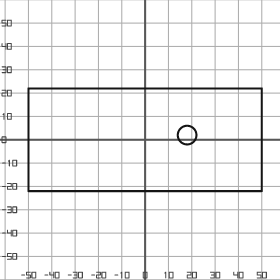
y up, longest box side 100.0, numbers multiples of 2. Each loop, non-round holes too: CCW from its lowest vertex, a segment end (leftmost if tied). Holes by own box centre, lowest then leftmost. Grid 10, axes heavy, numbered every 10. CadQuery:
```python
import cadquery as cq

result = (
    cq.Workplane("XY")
    .moveTo(-50.0, -22.0)
    .lineTo(50.0, -22.0)
    .lineTo(50.0, 22.0)
    .lineTo(-50.0, 22.0)
    .close()
    .moveTo(18.0, 2.0)
    .circle(4.0)
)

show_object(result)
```